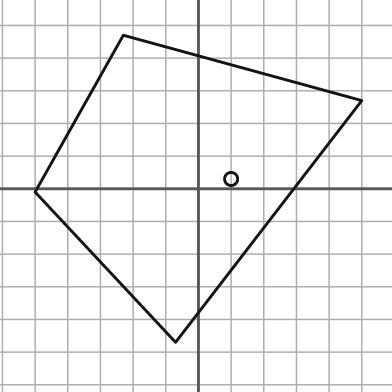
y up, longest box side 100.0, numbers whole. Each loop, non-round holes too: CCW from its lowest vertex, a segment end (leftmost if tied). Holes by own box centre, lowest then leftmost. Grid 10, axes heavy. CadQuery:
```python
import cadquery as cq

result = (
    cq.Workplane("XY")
    .moveTo(-7.0, -47.0)
    .lineTo(50.0, 27.0)
    .lineTo(-23.0, 47.0)
    .lineTo(-50.0, -1.0)
    .close()
    .moveTo(10.0, 3.0)
    .circle(2.0)
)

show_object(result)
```